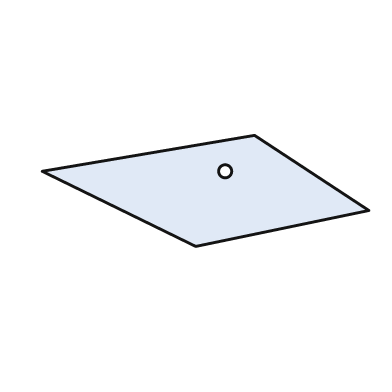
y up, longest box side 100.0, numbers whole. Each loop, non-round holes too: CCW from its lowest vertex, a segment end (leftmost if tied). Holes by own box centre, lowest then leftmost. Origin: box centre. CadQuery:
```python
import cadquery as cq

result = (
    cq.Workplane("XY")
    .moveTo(-3.0, -17.0)
    .lineTo(50.0, -6.0)
    .lineTo(15.0, 17.0)
    .lineTo(-50.0, 6.0)
    .close()
    .moveTo(6.0, 6.0)
    .circle(2.0)
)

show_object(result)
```